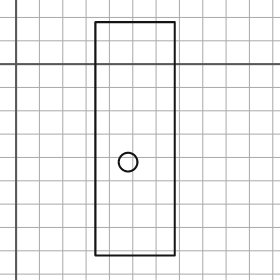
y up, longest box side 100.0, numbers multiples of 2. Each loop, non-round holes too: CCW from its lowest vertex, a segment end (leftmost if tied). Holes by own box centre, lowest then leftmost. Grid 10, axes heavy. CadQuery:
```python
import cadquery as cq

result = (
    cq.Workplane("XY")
    .moveTo(34.0, -82.0)
    .lineTo(68.0, -82.0)
    .lineTo(68.0, 18.0)
    .lineTo(34.0, 18.0)
    .close()
    .moveTo(48.0, -42.0)
    .circle(4.0)
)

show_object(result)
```